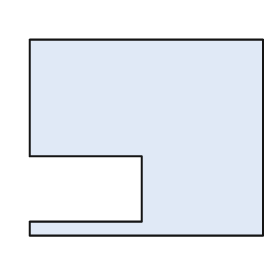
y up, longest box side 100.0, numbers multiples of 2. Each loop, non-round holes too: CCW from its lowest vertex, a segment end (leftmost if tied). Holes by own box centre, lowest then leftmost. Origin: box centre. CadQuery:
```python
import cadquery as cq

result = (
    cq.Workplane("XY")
    .moveTo(-50.0, -42.0)
    .lineTo(50.0, -42.0)
    .lineTo(50.0, 42.0)
    .lineTo(-50.0, 42.0)
    .lineTo(-50.0, -8.0)
    .lineTo(-2.0, -8.0)
    .lineTo(-2.0, -36.0)
    .lineTo(-50.0, -36.0)
    .close()
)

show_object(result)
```